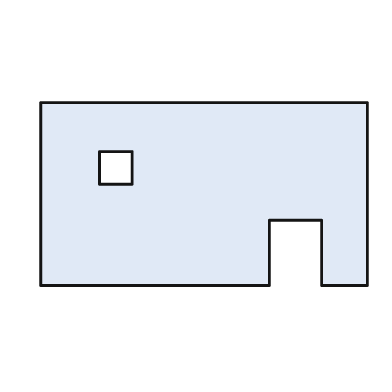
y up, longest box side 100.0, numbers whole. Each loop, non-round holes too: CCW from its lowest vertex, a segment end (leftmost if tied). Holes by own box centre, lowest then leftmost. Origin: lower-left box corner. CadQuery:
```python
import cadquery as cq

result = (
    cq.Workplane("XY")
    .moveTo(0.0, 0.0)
    .lineTo(70.0, 0.0)
    .lineTo(70.0, 20.0)
    .lineTo(86.0, 20.0)
    .lineTo(86.0, 0.0)
    .lineTo(100.0, 0.0)
    .lineTo(100.0, 56.0)
    .lineTo(0.0, 56.0)
    .close()
    .moveTo(18.0, 31.0)
    .lineTo(28.0, 31.0)
    .lineTo(28.0, 41.0)
    .lineTo(18.0, 41.0)
    .close()
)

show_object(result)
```